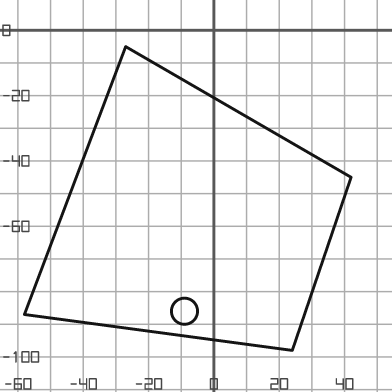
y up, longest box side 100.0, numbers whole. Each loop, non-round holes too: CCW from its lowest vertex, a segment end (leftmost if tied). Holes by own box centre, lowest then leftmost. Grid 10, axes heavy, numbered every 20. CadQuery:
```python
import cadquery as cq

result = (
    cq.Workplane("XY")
    .moveTo(24.0, -98.0)
    .lineTo(42.0, -45.0)
    .lineTo(-27.0, -5.0)
    .lineTo(-58.0, -87.0)
    .close()
    .moveTo(-9.0, -86.0)
    .circle(4.0)
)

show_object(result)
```